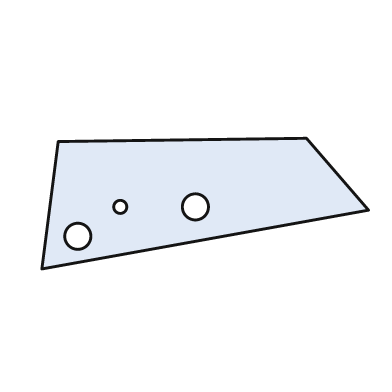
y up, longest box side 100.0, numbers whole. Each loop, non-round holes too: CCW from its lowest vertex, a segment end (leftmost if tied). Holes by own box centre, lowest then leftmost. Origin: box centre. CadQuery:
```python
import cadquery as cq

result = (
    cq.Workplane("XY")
    .moveTo(-50.0, -20.0)
    .lineTo(50.0, -2.0)
    .lineTo(31.0, 20.0)
    .lineTo(-45.0, 19.0)
    .close()
    .moveTo(-39.0, -10.0)
    .circle(4.0)
    .moveTo(-26.0, -1.0)
    .circle(2.0)
    .moveTo(-3.0, -1.0)
    .circle(4.0)
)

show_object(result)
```